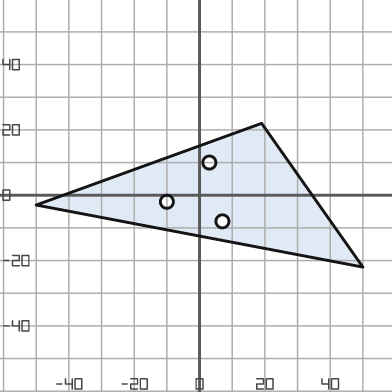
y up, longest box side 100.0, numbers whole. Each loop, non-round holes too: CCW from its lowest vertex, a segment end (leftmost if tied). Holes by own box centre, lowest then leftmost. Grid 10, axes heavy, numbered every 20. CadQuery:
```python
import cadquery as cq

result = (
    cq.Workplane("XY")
    .moveTo(50.0, -22.0)
    .lineTo(19.0, 22.0)
    .lineTo(-50.0, -3.0)
    .close()
    .moveTo(7.0, -8.0)
    .circle(2.0)
    .moveTo(-10.0, -2.0)
    .circle(2.0)
    .moveTo(3.0, 10.0)
    .circle(2.0)
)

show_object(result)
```